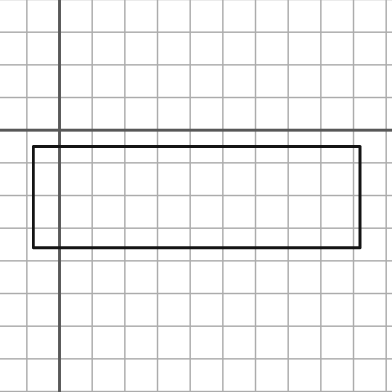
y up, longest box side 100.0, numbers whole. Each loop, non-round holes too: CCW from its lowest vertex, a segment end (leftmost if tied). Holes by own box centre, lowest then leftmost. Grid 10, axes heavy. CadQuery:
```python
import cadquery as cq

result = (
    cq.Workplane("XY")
    .moveTo(-8.0, -36.0)
    .lineTo(92.0, -36.0)
    .lineTo(92.0, -5.0)
    .lineTo(-8.0, -5.0)
    .close()
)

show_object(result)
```